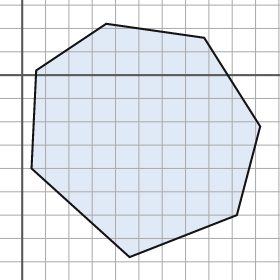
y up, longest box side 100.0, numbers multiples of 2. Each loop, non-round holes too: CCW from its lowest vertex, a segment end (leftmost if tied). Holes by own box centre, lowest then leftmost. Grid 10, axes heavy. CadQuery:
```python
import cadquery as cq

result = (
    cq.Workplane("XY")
    .moveTo(46.0, -78.0)
    .lineTo(92.0, -60.0)
    .lineTo(102.0, -22.0)
    .lineTo(78.0, 16.0)
    .lineTo(36.0, 22.0)
    .lineTo(6.0, 2.0)
    .lineTo(4.0, -40.0)
    .close()
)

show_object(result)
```